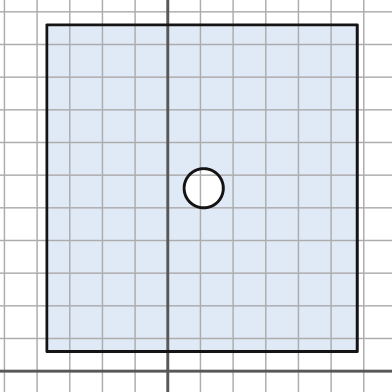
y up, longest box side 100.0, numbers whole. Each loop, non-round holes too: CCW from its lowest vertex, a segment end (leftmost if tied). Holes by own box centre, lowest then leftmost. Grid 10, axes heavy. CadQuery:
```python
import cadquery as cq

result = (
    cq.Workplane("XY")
    .moveTo(-37.0, 6.0)
    .lineTo(58.0, 6.0)
    .lineTo(58.0, 106.0)
    .lineTo(-37.0, 106.0)
    .close()
    .moveTo(11.0, 56.0)
    .circle(6.0)
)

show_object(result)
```